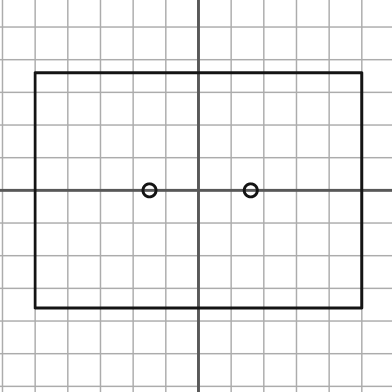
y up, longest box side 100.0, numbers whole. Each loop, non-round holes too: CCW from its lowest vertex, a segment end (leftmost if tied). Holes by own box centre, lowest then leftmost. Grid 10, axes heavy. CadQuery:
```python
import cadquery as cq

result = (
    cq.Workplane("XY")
    .moveTo(-50.0, -36.0)
    .lineTo(50.0, -36.0)
    .lineTo(50.0, 36.0)
    .lineTo(-50.0, 36.0)
    .close()
    .moveTo(-15.0, 0.0)
    .circle(2.0)
    .moveTo(16.0, 0.0)
    .circle(2.0)
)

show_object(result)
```